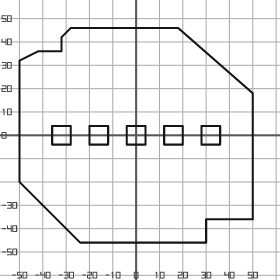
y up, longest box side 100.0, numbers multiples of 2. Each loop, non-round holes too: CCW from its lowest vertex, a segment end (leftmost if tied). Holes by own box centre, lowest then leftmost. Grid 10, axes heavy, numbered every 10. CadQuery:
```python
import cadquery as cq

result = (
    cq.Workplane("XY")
    .moveTo(-24.0, -46.0)
    .lineTo(30.0, -46.0)
    .lineTo(30.0, -36.0)
    .lineTo(50.0, -36.0)
    .lineTo(50.0, 18.0)
    .lineTo(18.0, 46.0)
    .lineTo(-28.0, 46.0)
    .lineTo(-32.0, 42.0)
    .lineTo(-32.0, 36.0)
    .lineTo(-42.0, 36.0)
    .lineTo(-50.0, 32.0)
    .lineTo(-50.0, -20.0)
    .close()
    .moveTo(-36.0, -4.0)
    .lineTo(-28.0, -4.0)
    .lineTo(-28.0, 4.0)
    .lineTo(-36.0, 4.0)
    .close()
    .moveTo(-20.0, -4.0)
    .lineTo(-12.0, -4.0)
    .lineTo(-12.0, 4.0)
    .lineTo(-20.0, 4.0)
    .close()
    .moveTo(-4.0, -4.0)
    .lineTo(4.0, -4.0)
    .lineTo(4.0, 4.0)
    .lineTo(-4.0, 4.0)
    .close()
    .moveTo(12.0, -4.0)
    .lineTo(20.0, -4.0)
    .lineTo(20.0, 4.0)
    .lineTo(12.0, 4.0)
    .close()
    .moveTo(28.0, -4.0)
    .lineTo(36.0, -4.0)
    .lineTo(36.0, 4.0)
    .lineTo(28.0, 4.0)
    .close()
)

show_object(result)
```